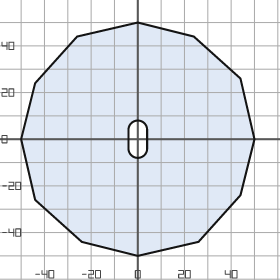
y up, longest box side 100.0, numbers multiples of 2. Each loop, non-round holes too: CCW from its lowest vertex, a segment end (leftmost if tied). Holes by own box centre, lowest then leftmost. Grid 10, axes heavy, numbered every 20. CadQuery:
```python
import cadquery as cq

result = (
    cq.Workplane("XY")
    .moveTo(0.0, -50.0)
    .lineTo(26.0, -44.0)
    .lineTo(44.0, -24.0)
    .lineTo(50.0, 0.0)
    .lineTo(44.0, 26.0)
    .lineTo(24.0, 44.0)
    .lineTo(0.0, 50.0)
    .lineTo(-26.0, 44.0)
    .lineTo(-44.0, 24.0)
    .lineTo(-50.0, 0.0)
    .lineTo(-44.0, -26.0)
    .lineTo(-24.0, -44.0)
    .close()
    .moveTo(-4.0, -4.0)
    .threePointArc((0.0, -8.0), (4.0, -4.0))
    .lineTo(4.0, 4.0)
    .threePointArc((0.0, 8.0), (-4.0, 4.0))
    .close()
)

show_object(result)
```